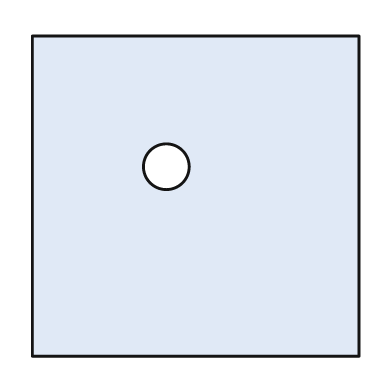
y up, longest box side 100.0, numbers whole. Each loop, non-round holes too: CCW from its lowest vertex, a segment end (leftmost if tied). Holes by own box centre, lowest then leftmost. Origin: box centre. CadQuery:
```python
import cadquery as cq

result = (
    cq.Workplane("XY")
    .moveTo(-50.0, -49.0)
    .lineTo(50.0, -49.0)
    .lineTo(50.0, 49.0)
    .lineTo(-50.0, 49.0)
    .close()
    .moveTo(-9.0, 9.0)
    .circle(7.0)
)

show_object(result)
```